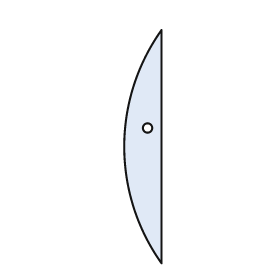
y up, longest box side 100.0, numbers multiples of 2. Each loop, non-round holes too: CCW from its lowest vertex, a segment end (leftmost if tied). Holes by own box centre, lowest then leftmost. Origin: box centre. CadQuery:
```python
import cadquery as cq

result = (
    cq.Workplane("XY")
    .moveTo(8.0, -50.0)
    .lineTo(8.0, 50.0)
    .threePointArc((-8.0, 0.0), (8.0, -50.0))
    .close()
    .moveTo(2.0, 8.0)
    .circle(2.0)
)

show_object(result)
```